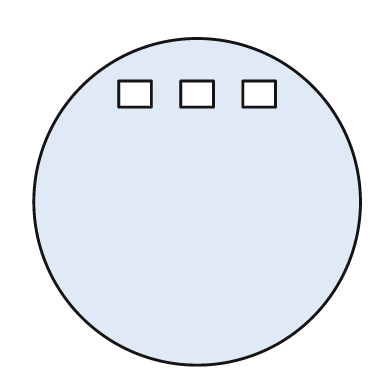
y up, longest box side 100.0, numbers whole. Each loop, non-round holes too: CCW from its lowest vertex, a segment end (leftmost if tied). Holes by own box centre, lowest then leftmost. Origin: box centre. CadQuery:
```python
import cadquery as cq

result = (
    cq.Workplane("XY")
    .moveTo(0.0, 0.0)
    .circle(50.0)
    .moveTo(-24.0, 29.0)
    .lineTo(-14.0, 29.0)
    .lineTo(-14.0, 37.0)
    .lineTo(-24.0, 37.0)
    .close()
    .moveTo(-5.0, 29.0)
    .lineTo(5.0, 29.0)
    .lineTo(5.0, 37.0)
    .lineTo(-5.0, 37.0)
    .close()
    .moveTo(14.0, 29.0)
    .lineTo(24.0, 29.0)
    .lineTo(24.0, 37.0)
    .lineTo(14.0, 37.0)
    .close()
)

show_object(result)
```